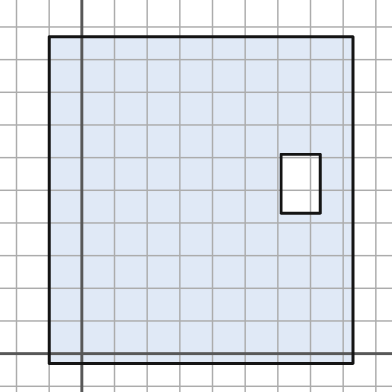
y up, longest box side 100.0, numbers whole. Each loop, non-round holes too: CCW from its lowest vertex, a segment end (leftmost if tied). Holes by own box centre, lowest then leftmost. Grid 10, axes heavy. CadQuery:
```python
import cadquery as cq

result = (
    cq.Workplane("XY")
    .moveTo(-10.0, -3.0)
    .lineTo(83.0, -3.0)
    .lineTo(83.0, 97.0)
    .lineTo(-10.0, 97.0)
    .close()
    .moveTo(61.0, 43.0)
    .lineTo(73.0, 43.0)
    .lineTo(73.0, 61.0)
    .lineTo(61.0, 61.0)
    .close()
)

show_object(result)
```